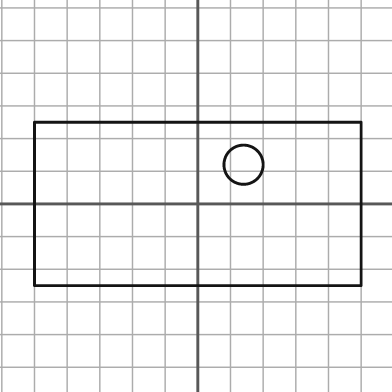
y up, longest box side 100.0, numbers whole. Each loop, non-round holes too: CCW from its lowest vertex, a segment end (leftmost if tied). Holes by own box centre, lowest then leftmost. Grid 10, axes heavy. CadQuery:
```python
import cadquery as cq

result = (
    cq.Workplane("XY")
    .moveTo(-50.0, -25.0)
    .lineTo(50.0, -25.0)
    .lineTo(50.0, 25.0)
    .lineTo(-50.0, 25.0)
    .close()
    .moveTo(14.0, 12.0)
    .circle(6.0)
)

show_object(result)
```